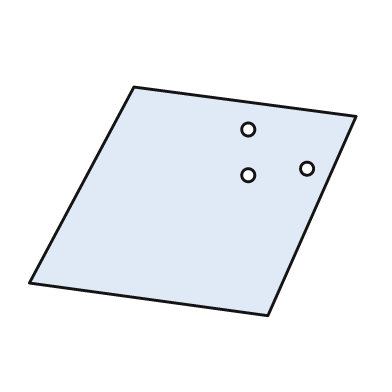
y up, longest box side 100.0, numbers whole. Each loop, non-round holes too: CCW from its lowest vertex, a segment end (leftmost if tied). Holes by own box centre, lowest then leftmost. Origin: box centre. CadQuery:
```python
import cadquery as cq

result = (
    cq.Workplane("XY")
    .moveTo(23.0, -35.0)
    .lineTo(50.0, 26.0)
    .lineTo(-18.0, 35.0)
    .lineTo(-50.0, -25.0)
    .close()
    .moveTo(17.0, 8.0)
    .circle(2.0)
    .moveTo(35.0, 10.0)
    .circle(2.0)
    .moveTo(17.0, 22.0)
    .circle(2.0)
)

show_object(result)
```